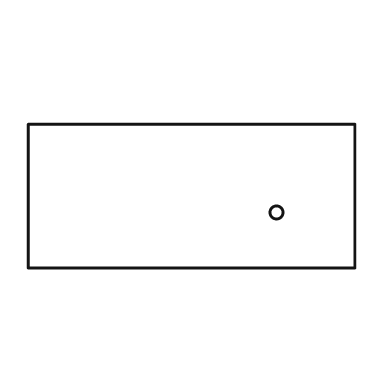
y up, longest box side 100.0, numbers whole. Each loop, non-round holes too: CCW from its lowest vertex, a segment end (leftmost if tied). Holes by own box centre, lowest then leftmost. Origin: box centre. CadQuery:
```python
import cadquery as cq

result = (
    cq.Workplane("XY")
    .moveTo(-50.0, -22.0)
    .lineTo(50.0, -22.0)
    .lineTo(50.0, 22.0)
    .lineTo(-50.0, 22.0)
    .close()
    .moveTo(26.0, -5.0)
    .circle(2.0)
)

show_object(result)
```